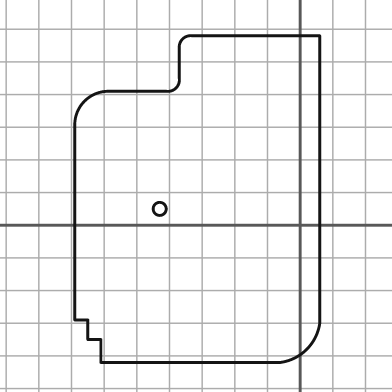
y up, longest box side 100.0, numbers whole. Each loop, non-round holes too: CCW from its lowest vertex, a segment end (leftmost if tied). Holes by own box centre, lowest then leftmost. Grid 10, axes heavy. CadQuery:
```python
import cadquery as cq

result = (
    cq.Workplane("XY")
    .moveTo(-61.0, -42.0)
    .lineTo(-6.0, -42.0)
    .threePointArc((2.0, -38.0), (6.0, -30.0))
    .lineTo(6.0, 58.0)
    .lineTo(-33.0, 58.0)
    .threePointArc((-36.0, 57.0), (-37.0, 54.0))
    .lineTo(-37.0, 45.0)
    .threePointArc((-38.0, 42.0), (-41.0, 41.0))
    .lineTo(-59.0, 41.0)
    .threePointArc((-66.0, 38.0), (-69.0, 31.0))
    .lineTo(-69.0, -29.0)
    .lineTo(-65.0, -29.0)
    .lineTo(-65.0, -35.0)
    .lineTo(-61.0, -35.0)
    .close()
    .moveTo(-43.0, 5.0)
    .circle(2.0)
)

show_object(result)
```